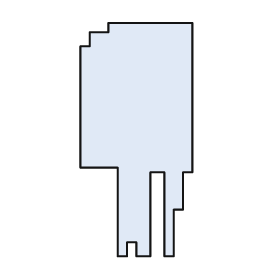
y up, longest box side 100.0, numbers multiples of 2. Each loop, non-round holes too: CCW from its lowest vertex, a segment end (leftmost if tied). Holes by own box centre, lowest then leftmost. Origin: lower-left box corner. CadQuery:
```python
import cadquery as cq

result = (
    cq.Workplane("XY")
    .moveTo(16.0, 0.0)
    .lineTo(20.0, 0.0)
    .lineTo(20.0, 6.0)
    .lineTo(24.0, 6.0)
    .lineTo(24.0, 0.0)
    .lineTo(30.0, 0.0)
    .lineTo(30.0, 36.0)
    .lineTo(36.0, 36.0)
    .lineTo(36.0, 0.0)
    .lineTo(40.0, 0.0)
    .lineTo(40.0, 20.0)
    .lineTo(44.0, 20.0)
    .lineTo(44.0, 36.0)
    .lineTo(48.0, 36.0)
    .lineTo(48.0, 100.0)
    .lineTo(12.0, 100.0)
    .lineTo(12.0, 96.0)
    .lineTo(4.0, 96.0)
    .lineTo(4.0, 90.0)
    .lineTo(0.0, 90.0)
    .lineTo(0.0, 38.0)
    .lineTo(16.0, 38.0)
    .close()
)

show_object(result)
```